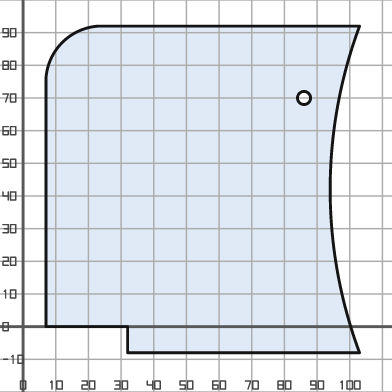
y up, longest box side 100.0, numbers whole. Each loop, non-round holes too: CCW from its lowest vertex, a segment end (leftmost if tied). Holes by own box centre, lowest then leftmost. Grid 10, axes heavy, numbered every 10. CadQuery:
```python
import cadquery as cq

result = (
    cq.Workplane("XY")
    .moveTo(32.0, -8.0)
    .lineTo(103.0, -8.0)
    .threePointArc((94.0, 42.0), (103.0, 92.0))
    .lineTo(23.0, 92.0)
    .threePointArc((12.0, 87.0), (7.0, 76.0))
    .lineTo(7.0, 0.0)
    .lineTo(32.0, 0.0)
    .close()
    .moveTo(86.0, 70.0)
    .circle(2.0)
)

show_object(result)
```